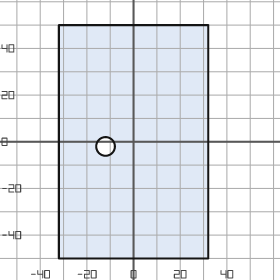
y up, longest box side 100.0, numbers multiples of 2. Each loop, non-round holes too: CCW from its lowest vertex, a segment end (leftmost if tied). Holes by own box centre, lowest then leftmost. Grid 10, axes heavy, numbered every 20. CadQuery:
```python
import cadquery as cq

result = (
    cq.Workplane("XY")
    .moveTo(-32.0, -50.0)
    .lineTo(32.0, -50.0)
    .lineTo(32.0, 50.0)
    .lineTo(-32.0, 50.0)
    .close()
    .moveTo(-12.0, -2.0)
    .circle(4.0)
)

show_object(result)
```